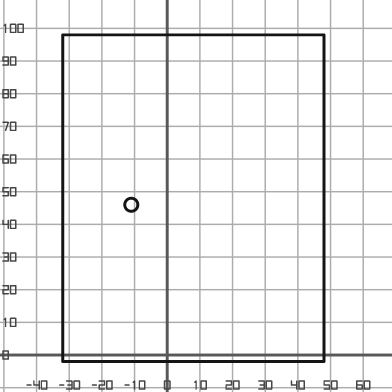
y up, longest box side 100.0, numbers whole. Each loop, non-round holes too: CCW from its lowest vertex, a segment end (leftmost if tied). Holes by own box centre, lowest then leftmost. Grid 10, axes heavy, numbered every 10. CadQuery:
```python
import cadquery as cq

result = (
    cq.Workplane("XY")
    .moveTo(-32.0, -2.0)
    .lineTo(48.0, -2.0)
    .lineTo(48.0, 98.0)
    .lineTo(-32.0, 98.0)
    .close()
    .moveTo(-11.0, 46.0)
    .circle(2.0)
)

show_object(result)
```